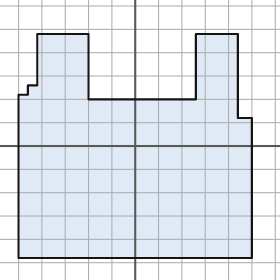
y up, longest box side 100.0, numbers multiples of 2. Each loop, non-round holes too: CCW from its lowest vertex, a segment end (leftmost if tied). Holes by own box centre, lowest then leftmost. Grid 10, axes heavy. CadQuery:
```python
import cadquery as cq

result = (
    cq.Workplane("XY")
    .moveTo(-50.0, -48.0)
    .lineTo(50.0, -48.0)
    .lineTo(50.0, 12.0)
    .lineTo(44.0, 12.0)
    .lineTo(44.0, 48.0)
    .lineTo(26.0, 48.0)
    .lineTo(26.0, 20.0)
    .lineTo(-20.0, 20.0)
    .lineTo(-20.0, 48.0)
    .lineTo(-42.0, 48.0)
    .lineTo(-42.0, 26.0)
    .lineTo(-46.0, 26.0)
    .lineTo(-46.0, 22.0)
    .lineTo(-50.0, 22.0)
    .close()
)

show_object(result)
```